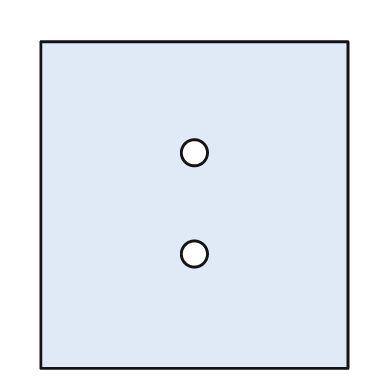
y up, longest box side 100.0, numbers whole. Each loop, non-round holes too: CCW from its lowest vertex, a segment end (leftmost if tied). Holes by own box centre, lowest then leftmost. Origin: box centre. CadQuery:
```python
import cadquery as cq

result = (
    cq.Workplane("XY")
    .moveTo(-47.0, -50.0)
    .lineTo(47.0, -50.0)
    .lineTo(47.0, 50.0)
    .lineTo(-47.0, 50.0)
    .close()
    .moveTo(0.0, -15.0)
    .circle(4.0)
    .moveTo(0.0, 16.0)
    .circle(4.0)
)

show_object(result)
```